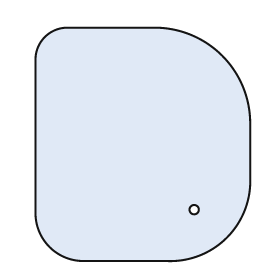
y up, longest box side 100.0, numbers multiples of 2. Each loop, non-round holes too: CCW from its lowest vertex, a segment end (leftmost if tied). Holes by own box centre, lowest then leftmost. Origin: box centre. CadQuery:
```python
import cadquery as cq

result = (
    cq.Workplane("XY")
    .moveTo(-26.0, -50.0)
    .lineTo(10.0, -50.0)
    .threePointArc((36.0, -40.0), (46.0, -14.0))
    .lineTo(46.0, 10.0)
    .threePointArc((34.0, 38.0), (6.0, 50.0))
    .lineTo(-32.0, 50.0)
    .threePointArc((-42.0, 46.0), (-46.0, 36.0))
    .lineTo(-46.0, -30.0)
    .threePointArc((-40.0, -44.0), (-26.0, -50.0))
    .close()
    .moveTo(22.0, -28.0)
    .circle(2.0)
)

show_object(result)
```